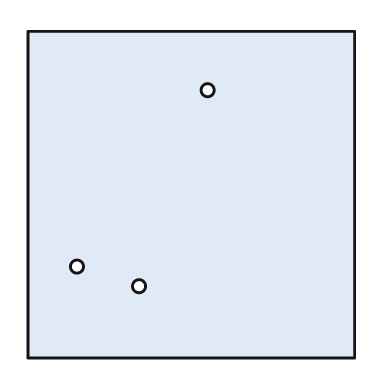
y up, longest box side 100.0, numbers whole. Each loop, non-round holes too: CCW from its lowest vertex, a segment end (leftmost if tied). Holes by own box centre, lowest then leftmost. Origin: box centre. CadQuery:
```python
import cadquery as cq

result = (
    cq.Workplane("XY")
    .moveTo(-50.0, -50.0)
    .lineTo(50.0, -50.0)
    .lineTo(50.0, 50.0)
    .lineTo(-50.0, 50.0)
    .close()
    .moveTo(-16.0, -28.0)
    .circle(2.0)
    .moveTo(-35.0, -22.0)
    .circle(2.0)
    .moveTo(5.0, 32.0)
    .circle(2.0)
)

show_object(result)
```